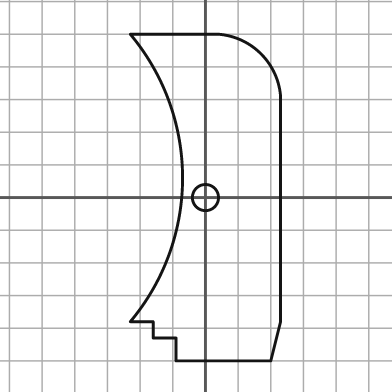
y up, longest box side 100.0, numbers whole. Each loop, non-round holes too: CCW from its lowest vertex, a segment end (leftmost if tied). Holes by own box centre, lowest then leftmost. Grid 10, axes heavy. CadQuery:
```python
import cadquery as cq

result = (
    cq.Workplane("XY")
    .moveTo(-9.0, -50.0)
    .lineTo(20.0, -50.0)
    .lineTo(23.0, -38.0)
    .lineTo(23.0, 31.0)
    .threePointArc((17.0, 44.0), (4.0, 50.0))
    .lineTo(-23.0, 50.0)
    .threePointArc((-7.0, 6.0), (-23.0, -38.0))
    .lineTo(-16.0, -38.0)
    .lineTo(-16.0, -43.0)
    .lineTo(-9.0, -43.0)
    .close()
    .moveTo(0.0, 0.0)
    .circle(4.0)
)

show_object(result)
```